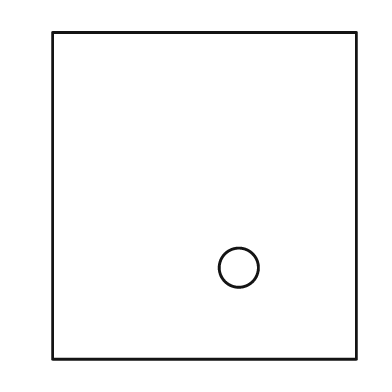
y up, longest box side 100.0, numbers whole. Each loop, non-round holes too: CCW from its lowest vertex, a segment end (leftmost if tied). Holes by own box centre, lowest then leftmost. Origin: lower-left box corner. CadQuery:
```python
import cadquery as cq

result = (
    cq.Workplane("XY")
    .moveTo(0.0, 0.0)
    .lineTo(93.0, 0.0)
    .lineTo(93.0, 100.0)
    .lineTo(0.0, 100.0)
    .close()
    .moveTo(57.0, 28.0)
    .circle(6.0)
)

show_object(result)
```